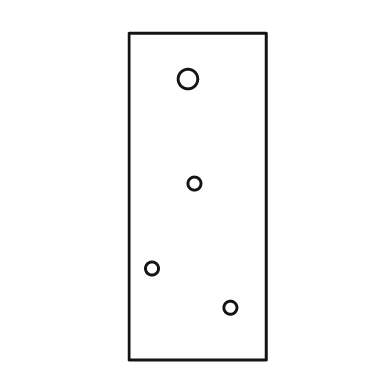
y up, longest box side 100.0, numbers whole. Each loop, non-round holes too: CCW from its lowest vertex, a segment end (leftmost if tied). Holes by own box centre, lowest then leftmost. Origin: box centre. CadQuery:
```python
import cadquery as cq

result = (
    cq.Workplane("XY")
    .moveTo(-21.0, -50.0)
    .lineTo(21.0, -50.0)
    .lineTo(21.0, 50.0)
    .lineTo(-21.0, 50.0)
    .close()
    .moveTo(10.0, -34.0)
    .circle(2.0)
    .moveTo(-14.0, -22.0)
    .circle(2.0)
    .moveTo(-1.0, 4.0)
    .circle(2.0)
    .moveTo(-3.0, 36.0)
    .circle(3.0)
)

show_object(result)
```